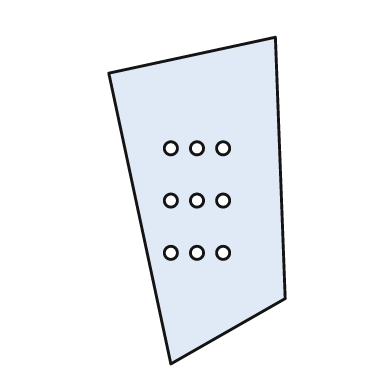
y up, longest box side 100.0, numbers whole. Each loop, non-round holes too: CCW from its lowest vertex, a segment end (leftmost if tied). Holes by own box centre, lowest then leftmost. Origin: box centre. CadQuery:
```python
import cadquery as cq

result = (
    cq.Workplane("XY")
    .moveTo(-8.0, -50.0)
    .lineTo(27.0, -30.0)
    .lineTo(24.0, 50.0)
    .lineTo(-27.0, 39.0)
    .close()
    .moveTo(-8.0, -16.0)
    .circle(2.0)
    .moveTo(0.0, -16.0)
    .circle(2.0)
    .moveTo(8.0, -16.0)
    .circle(2.0)
    .moveTo(-8.0, 0.0)
    .circle(2.0)
    .moveTo(0.0, 0.0)
    .circle(2.0)
    .moveTo(8.0, 0.0)
    .circle(2.0)
    .moveTo(-8.0, 16.0)
    .circle(2.0)
    .moveTo(0.0, 16.0)
    .circle(2.0)
    .moveTo(8.0, 16.0)
    .circle(2.0)
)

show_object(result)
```